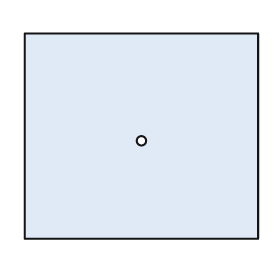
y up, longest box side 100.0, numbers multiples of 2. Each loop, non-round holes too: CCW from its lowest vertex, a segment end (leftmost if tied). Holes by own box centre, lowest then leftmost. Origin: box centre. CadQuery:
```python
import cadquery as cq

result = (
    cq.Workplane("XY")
    .moveTo(-50.0, -44.0)
    .lineTo(50.0, -44.0)
    .lineTo(50.0, 44.0)
    .lineTo(-50.0, 44.0)
    .close()
    .moveTo(0.0, -2.0)
    .circle(2.0)
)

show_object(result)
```